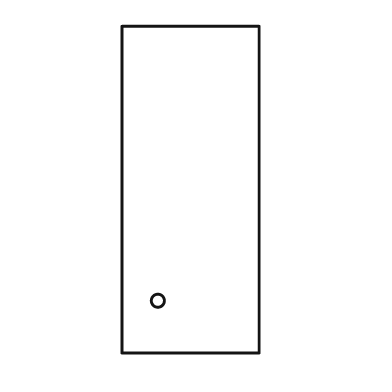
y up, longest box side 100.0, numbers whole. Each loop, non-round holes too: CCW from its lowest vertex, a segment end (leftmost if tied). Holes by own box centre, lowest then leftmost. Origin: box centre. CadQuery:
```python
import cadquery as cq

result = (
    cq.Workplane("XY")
    .moveTo(-21.0, -50.0)
    .lineTo(21.0, -50.0)
    .lineTo(21.0, 50.0)
    .lineTo(-21.0, 50.0)
    .close()
    .moveTo(-10.0, -34.0)
    .circle(2.0)
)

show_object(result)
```